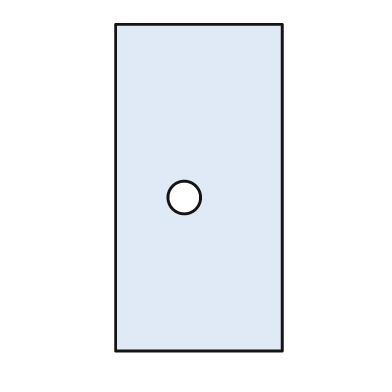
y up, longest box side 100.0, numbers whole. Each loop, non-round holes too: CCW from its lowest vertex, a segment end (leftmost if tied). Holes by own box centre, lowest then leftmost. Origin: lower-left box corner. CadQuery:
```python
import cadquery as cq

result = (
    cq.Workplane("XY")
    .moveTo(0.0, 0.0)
    .lineTo(51.0, 0.0)
    .lineTo(51.0, 100.0)
    .lineTo(0.0, 100.0)
    .close()
    .moveTo(21.0, 47.0)
    .circle(5.0)
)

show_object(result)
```